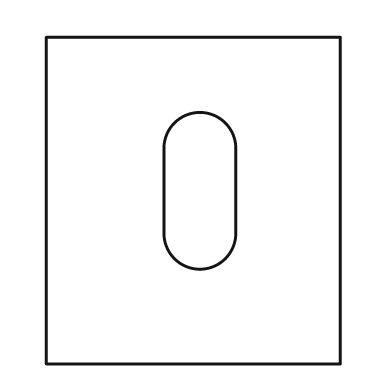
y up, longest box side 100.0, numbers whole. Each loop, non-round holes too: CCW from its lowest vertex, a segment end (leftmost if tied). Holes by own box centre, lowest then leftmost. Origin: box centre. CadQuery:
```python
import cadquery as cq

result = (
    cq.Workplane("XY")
    .moveTo(-45.0, -50.0)
    .lineTo(45.0, -50.0)
    .lineTo(45.0, 50.0)
    .lineTo(-45.0, 50.0)
    .close()
    .moveTo(-9.0, -10.0)
    .threePointArc((2.0, -21.0), (13.0, -10.0))
    .lineTo(13.0, 16.0)
    .threePointArc((2.0, 27.0), (-9.0, 16.0))
    .close()
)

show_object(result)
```